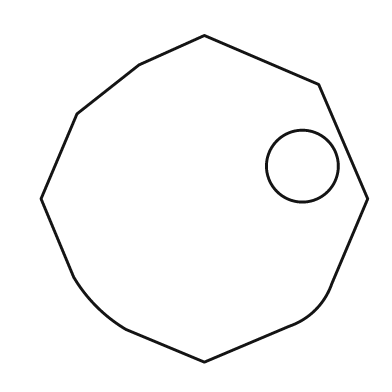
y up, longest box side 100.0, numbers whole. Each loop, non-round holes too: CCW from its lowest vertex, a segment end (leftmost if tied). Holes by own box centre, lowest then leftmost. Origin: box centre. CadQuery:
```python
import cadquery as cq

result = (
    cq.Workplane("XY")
    .moveTo(0.0, -50.0)
    .lineTo(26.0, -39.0)
    .threePointArc((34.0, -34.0), (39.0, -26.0))
    .lineTo(50.0, 0.0)
    .lineTo(35.0, 35.0)
    .lineTo(0.0, 50.0)
    .lineTo(-20.0, 41.0)
    .lineTo(-39.0, 26.0)
    .lineTo(-50.0, 0.0)
    .lineTo(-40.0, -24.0)
    .threePointArc((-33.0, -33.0), (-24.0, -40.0))
    .close()
    .moveTo(30.0, 10.0)
    .circle(11.0)
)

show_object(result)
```